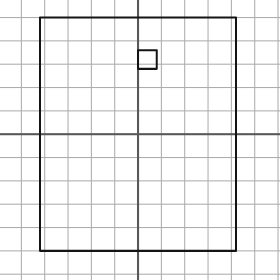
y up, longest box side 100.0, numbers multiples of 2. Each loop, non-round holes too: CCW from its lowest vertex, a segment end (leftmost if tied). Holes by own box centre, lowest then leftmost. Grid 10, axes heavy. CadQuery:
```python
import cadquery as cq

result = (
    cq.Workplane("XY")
    .moveTo(-42.0, -50.0)
    .lineTo(42.0, -50.0)
    .lineTo(42.0, 50.0)
    .lineTo(-42.0, 50.0)
    .close()
    .moveTo(0.0, 28.0)
    .lineTo(8.0, 28.0)
    .lineTo(8.0, 36.0)
    .lineTo(0.0, 36.0)
    .close()
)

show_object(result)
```